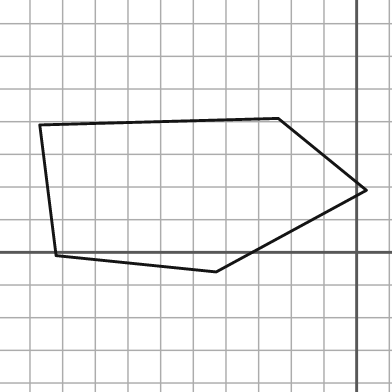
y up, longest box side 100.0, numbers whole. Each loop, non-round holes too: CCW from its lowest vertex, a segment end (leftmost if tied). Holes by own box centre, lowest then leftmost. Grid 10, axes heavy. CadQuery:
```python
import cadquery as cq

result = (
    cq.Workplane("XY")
    .moveTo(-43.0, -6.0)
    .lineTo(3.0, 19.0)
    .lineTo(-24.0, 41.0)
    .lineTo(-97.0, 39.0)
    .lineTo(-92.0, -1.0)
    .close()
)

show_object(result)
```